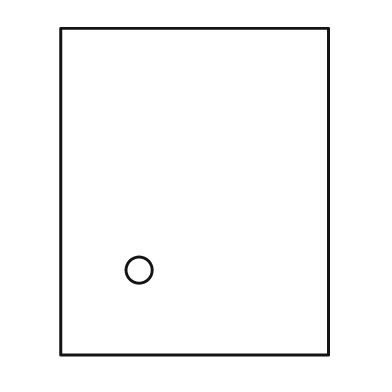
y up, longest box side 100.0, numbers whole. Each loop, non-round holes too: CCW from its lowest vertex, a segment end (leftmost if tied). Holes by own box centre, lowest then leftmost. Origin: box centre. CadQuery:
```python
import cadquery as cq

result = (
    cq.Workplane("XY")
    .moveTo(-41.0, -50.0)
    .lineTo(41.0, -50.0)
    .lineTo(41.0, 50.0)
    .lineTo(-41.0, 50.0)
    .close()
    .moveTo(-17.0, -24.0)
    .circle(4.0)
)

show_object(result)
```